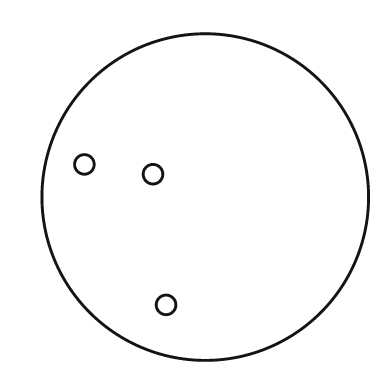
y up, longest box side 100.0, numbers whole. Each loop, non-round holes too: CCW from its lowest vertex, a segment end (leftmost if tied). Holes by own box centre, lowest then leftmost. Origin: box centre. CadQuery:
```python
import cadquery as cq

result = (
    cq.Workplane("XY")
    .moveTo(0.0, 0.0)
    .circle(50.0)
    .moveTo(-12.0, -33.0)
    .circle(3.0)
    .moveTo(-16.0, 7.0)
    .circle(3.0)
    .moveTo(-37.0, 10.0)
    .circle(3.0)
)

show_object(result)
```